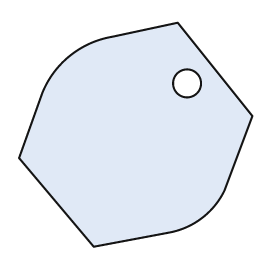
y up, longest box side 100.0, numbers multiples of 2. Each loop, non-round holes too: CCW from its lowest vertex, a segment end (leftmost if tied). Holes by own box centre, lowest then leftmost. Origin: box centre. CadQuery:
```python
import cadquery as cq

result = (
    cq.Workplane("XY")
    .moveTo(-18.0, -48.0)
    .lineTo(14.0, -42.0)
    .threePointArc((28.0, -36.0), (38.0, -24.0))
    .lineTo(50.0, 8.0)
    .lineTo(18.0, 48.0)
    .lineTo(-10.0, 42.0)
    .threePointArc((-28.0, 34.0), (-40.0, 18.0))
    .lineTo(-50.0, -10.0)
    .close()
    .moveTo(22.0, 22.0)
    .circle(6.0)
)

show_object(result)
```